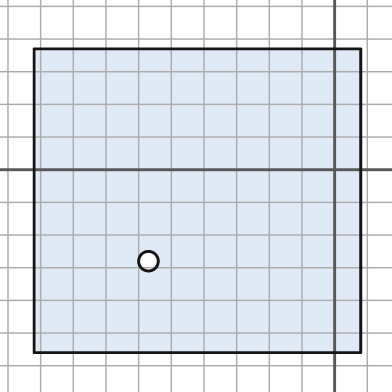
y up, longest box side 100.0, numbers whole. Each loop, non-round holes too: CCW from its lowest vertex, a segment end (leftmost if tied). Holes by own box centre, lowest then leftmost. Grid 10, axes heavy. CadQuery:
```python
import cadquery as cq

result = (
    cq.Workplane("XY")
    .moveTo(-92.0, -56.0)
    .lineTo(8.0, -56.0)
    .lineTo(8.0, 37.0)
    .lineTo(-92.0, 37.0)
    .close()
    .moveTo(-57.0, -28.0)
    .circle(3.0)
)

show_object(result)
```